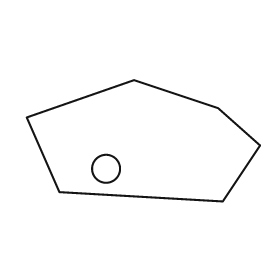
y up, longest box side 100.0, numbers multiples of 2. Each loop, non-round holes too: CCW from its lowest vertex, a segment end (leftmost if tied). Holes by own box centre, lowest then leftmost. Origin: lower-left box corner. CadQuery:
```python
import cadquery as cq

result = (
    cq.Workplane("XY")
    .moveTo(84.0, 0.0)
    .lineTo(100.0, 24.0)
    .lineTo(82.0, 40.0)
    .lineTo(46.0, 52.0)
    .lineTo(0.0, 36.0)
    .lineTo(14.0, 4.0)
    .close()
    .moveTo(34.0, 14.0)
    .circle(6.0)
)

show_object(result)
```